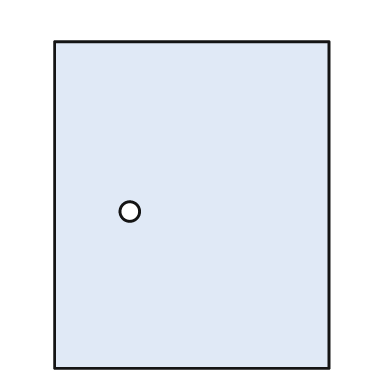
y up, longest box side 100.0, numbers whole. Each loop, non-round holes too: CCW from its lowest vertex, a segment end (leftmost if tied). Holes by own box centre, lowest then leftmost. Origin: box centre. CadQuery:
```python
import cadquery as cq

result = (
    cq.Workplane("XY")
    .moveTo(-42.0, -50.0)
    .lineTo(42.0, -50.0)
    .lineTo(42.0, 50.0)
    .lineTo(-42.0, 50.0)
    .close()
    .moveTo(-19.0, -2.0)
    .circle(3.0)
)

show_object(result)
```